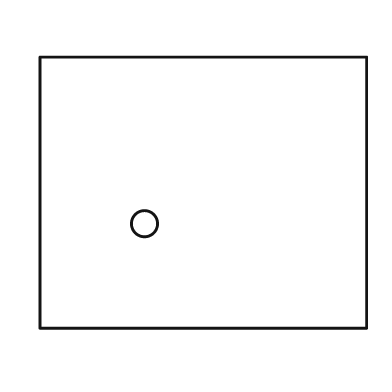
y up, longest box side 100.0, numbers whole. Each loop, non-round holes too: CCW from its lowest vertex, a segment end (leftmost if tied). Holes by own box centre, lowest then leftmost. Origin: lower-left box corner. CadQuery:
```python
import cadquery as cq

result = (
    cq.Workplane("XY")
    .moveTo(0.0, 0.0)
    .lineTo(100.0, 0.0)
    .lineTo(100.0, 83.0)
    .lineTo(0.0, 83.0)
    .close()
    .moveTo(32.0, 32.0)
    .circle(4.0)
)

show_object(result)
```